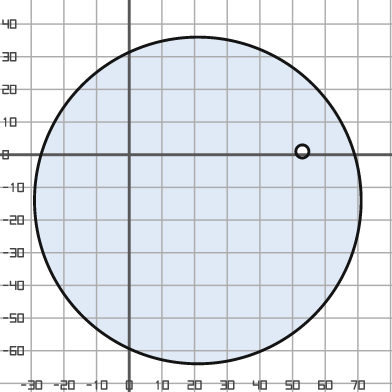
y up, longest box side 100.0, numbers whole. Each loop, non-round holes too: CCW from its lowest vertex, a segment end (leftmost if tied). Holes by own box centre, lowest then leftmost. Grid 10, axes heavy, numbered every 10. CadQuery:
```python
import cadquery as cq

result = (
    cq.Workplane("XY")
    .moveTo(21.0, -14.0)
    .circle(50.0)
    .moveTo(53.0, 1.0)
    .circle(2.0)
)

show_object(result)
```